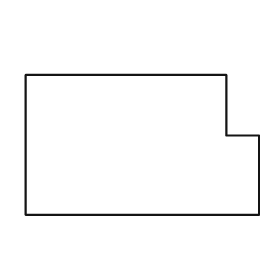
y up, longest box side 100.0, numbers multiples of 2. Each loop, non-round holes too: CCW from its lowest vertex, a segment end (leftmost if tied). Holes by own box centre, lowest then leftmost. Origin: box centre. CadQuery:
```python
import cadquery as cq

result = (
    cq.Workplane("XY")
    .moveTo(-50.0, -30.0)
    .lineTo(50.0, -30.0)
    .lineTo(50.0, 4.0)
    .lineTo(36.0, 4.0)
    .lineTo(36.0, 30.0)
    .lineTo(-50.0, 30.0)
    .close()
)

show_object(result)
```